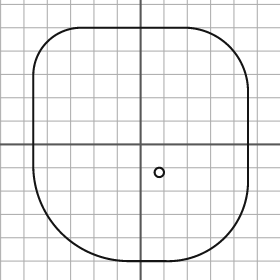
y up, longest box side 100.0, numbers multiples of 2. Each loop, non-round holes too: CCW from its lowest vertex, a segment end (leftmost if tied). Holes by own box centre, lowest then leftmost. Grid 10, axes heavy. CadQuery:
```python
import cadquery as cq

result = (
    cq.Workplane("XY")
    .moveTo(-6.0, -50.0)
    .lineTo(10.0, -50.0)
    .threePointArc((36.0, -40.0), (46.0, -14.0))
    .lineTo(46.0, 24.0)
    .threePointArc((38.0, 42.0), (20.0, 50.0))
    .lineTo(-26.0, 50.0)
    .threePointArc((-40.0, 44.0), (-46.0, 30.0))
    .lineTo(-46.0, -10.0)
    .threePointArc((-34.0, -38.0), (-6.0, -50.0))
    .close()
    .moveTo(8.0, -12.0)
    .circle(2.0)
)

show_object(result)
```